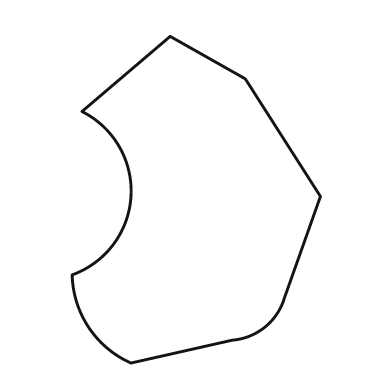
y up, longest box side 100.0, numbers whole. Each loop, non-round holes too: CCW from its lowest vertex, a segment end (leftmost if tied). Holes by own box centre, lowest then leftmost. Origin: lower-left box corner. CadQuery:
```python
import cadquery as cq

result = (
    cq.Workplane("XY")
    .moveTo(18.0, 0.0)
    .lineTo(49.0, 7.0)
    .threePointArc((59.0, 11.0), (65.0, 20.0))
    .lineTo(76.0, 51.0)
    .lineTo(53.0, 87.0)
    .lineTo(30.0, 100.0)
    .lineTo(3.0, 77.0)
    .threePointArc((18.0, 51.0), (0.0, 27.0))
    .threePointArc((5.0, 11.0), (18.0, 0.0))
    .close()
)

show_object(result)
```